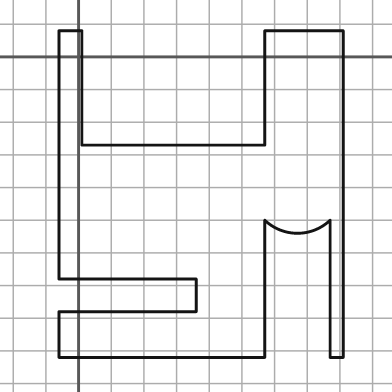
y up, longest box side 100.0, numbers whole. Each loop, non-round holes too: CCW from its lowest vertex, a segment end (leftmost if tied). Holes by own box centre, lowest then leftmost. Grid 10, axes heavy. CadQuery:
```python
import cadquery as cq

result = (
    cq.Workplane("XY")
    .moveTo(-6.0, -92.0)
    .lineTo(57.0, -92.0)
    .lineTo(57.0, -50.0)
    .threePointArc((67.0, -54.0), (77.0, -50.0))
    .lineTo(77.0, -92.0)
    .lineTo(81.0, -92.0)
    .lineTo(81.0, 8.0)
    .lineTo(57.0, 8.0)
    .lineTo(57.0, -27.0)
    .lineTo(1.0, -27.0)
    .lineTo(1.0, 8.0)
    .lineTo(-6.0, 8.0)
    .lineTo(-6.0, -68.0)
    .lineTo(36.0, -68.0)
    .lineTo(36.0, -78.0)
    .lineTo(-6.0, -78.0)
    .close()
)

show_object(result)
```